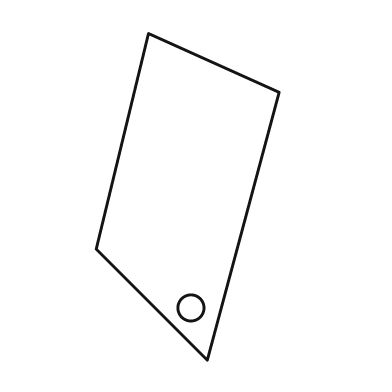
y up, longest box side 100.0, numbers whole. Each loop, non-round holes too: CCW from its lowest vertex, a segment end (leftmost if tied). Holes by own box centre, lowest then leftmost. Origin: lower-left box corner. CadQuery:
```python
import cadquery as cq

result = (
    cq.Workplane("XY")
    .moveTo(34.0, 0.0)
    .lineTo(56.0, 82.0)
    .lineTo(16.0, 100.0)
    .lineTo(0.0, 34.0)
    .close()
    .moveTo(29.0, 16.0)
    .circle(4.0)
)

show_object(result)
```